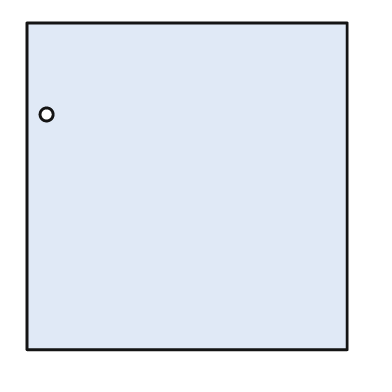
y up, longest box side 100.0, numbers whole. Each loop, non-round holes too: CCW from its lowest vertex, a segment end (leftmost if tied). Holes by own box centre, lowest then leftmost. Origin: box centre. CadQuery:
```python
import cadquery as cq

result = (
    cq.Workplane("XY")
    .moveTo(-49.0, -50.0)
    .lineTo(49.0, -50.0)
    .lineTo(49.0, 50.0)
    .lineTo(-49.0, 50.0)
    .close()
    .moveTo(-43.0, 22.0)
    .circle(2.0)
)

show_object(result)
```